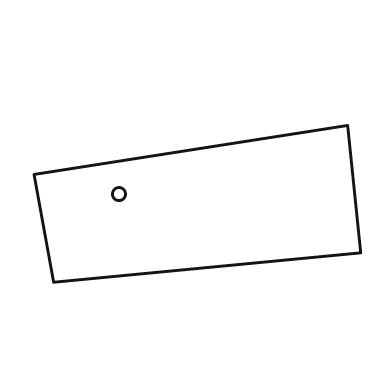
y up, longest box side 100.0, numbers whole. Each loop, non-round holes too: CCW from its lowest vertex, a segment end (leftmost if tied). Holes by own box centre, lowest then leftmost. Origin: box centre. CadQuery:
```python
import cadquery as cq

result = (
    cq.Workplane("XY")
    .moveTo(-44.0, -24.0)
    .lineTo(50.0, -15.0)
    .lineTo(46.0, 24.0)
    .lineTo(-50.0, 9.0)
    .close()
    .moveTo(-24.0, 3.0)
    .circle(2.0)
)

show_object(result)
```